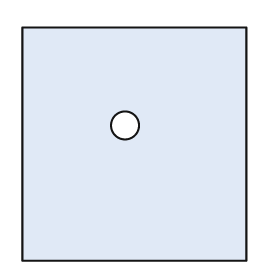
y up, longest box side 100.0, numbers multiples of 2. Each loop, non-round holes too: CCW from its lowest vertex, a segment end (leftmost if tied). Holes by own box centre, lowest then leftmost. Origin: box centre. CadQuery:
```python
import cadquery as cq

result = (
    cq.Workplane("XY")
    .moveTo(-48.0, -50.0)
    .lineTo(48.0, -50.0)
    .lineTo(48.0, 50.0)
    .lineTo(-48.0, 50.0)
    .close()
    .moveTo(-4.0, 8.0)
    .circle(6.0)
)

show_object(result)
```